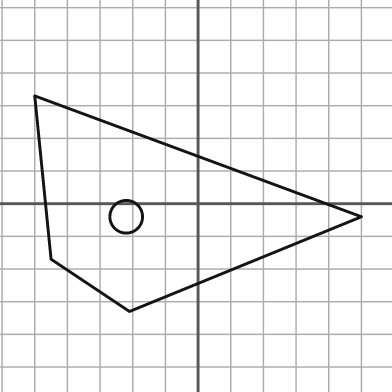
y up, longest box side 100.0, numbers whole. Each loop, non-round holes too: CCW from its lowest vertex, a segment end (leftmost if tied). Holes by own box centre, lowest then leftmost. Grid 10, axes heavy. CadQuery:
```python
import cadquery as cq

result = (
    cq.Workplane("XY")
    .moveTo(-21.0, -33.0)
    .lineTo(50.0, -4.0)
    .lineTo(-50.0, 33.0)
    .lineTo(-45.0, -17.0)
    .close()
    .moveTo(-22.0, -4.0)
    .circle(5.0)
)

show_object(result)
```